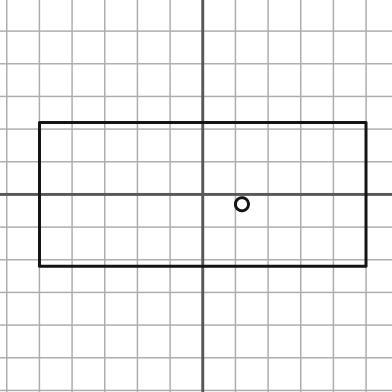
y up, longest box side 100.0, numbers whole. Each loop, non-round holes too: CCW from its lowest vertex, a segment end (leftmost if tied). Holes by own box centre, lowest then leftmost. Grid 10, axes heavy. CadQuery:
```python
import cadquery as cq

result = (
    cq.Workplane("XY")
    .moveTo(-50.0, -22.0)
    .lineTo(50.0, -22.0)
    .lineTo(50.0, 22.0)
    .lineTo(-50.0, 22.0)
    .close()
    .moveTo(12.0, -3.0)
    .circle(2.0)
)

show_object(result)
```